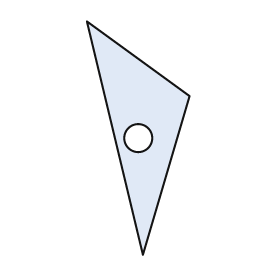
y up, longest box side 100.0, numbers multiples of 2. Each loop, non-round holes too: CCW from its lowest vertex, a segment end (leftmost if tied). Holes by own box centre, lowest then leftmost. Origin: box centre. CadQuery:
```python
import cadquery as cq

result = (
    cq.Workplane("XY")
    .moveTo(2.0, -50.0)
    .lineTo(22.0, 18.0)
    .lineTo(-22.0, 50.0)
    .close()
    .moveTo(0.0, 0.0)
    .circle(6.0)
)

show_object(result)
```